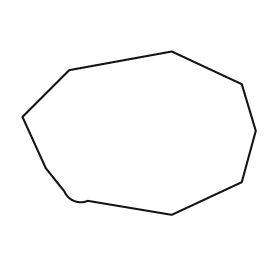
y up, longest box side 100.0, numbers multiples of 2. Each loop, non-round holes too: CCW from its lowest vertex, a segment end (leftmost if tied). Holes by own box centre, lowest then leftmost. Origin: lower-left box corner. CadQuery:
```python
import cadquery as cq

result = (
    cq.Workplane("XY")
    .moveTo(64.0, 0.0)
    .lineTo(94.0, 14.0)
    .lineTo(100.0, 36.0)
    .lineTo(94.0, 56.0)
    .lineTo(64.0, 70.0)
    .lineTo(20.0, 62.0)
    .lineTo(0.0, 42.0)
    .lineTo(10.0, 20.0)
    .lineTo(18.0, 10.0)
    .threePointArc((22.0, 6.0), (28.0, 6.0))
    .close()
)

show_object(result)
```